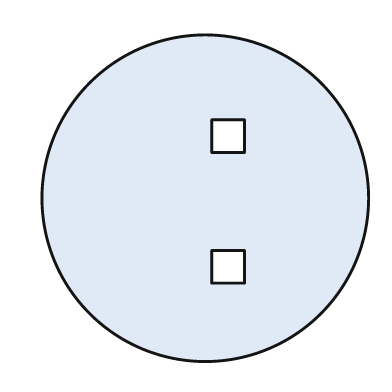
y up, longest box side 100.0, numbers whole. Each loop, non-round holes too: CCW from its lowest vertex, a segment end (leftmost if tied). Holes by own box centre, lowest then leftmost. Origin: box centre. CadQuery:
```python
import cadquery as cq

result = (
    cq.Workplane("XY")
    .moveTo(0.0, 0.0)
    .circle(50.0)
    .moveTo(2.0, -26.0)
    .lineTo(12.0, -26.0)
    .lineTo(12.0, -16.0)
    .lineTo(2.0, -16.0)
    .close()
    .moveTo(2.0, 14.0)
    .lineTo(12.0, 14.0)
    .lineTo(12.0, 24.0)
    .lineTo(2.0, 24.0)
    .close()
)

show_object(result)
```